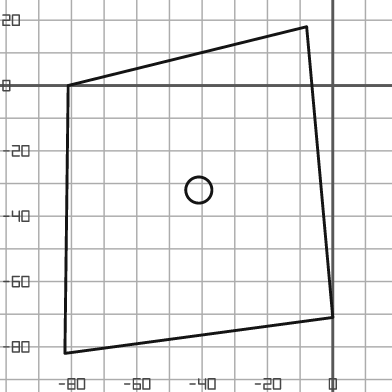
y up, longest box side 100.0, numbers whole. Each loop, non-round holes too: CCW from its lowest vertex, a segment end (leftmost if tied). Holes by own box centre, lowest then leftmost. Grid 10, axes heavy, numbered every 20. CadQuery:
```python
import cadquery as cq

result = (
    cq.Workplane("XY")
    .moveTo(-82.0, -82.0)
    .lineTo(0.0, -71.0)
    .lineTo(-8.0, 18.0)
    .lineTo(-81.0, 0.0)
    .close()
    .moveTo(-41.0, -32.0)
    .circle(4.0)
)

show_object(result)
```